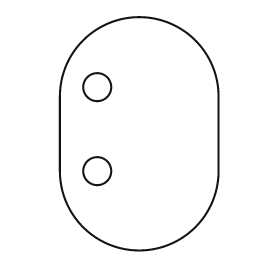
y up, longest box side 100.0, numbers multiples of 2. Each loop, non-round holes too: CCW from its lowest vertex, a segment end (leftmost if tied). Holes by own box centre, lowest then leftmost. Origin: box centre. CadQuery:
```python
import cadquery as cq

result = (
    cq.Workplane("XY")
    .moveTo(-34.0, -16.0)
    .threePointArc((0.0, -50.0), (34.0, -16.0))
    .lineTo(34.0, 16.0)
    .threePointArc((0.0, 50.0), (-34.0, 16.0))
    .close()
    .moveTo(-18.0, -16.0)
    .circle(6.0)
    .moveTo(-18.0, 20.0)
    .circle(6.0)
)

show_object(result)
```